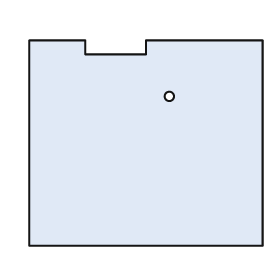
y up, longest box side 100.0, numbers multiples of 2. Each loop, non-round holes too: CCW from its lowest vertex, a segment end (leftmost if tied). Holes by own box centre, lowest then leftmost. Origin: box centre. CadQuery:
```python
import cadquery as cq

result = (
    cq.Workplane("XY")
    .moveTo(-50.0, -44.0)
    .lineTo(50.0, -44.0)
    .lineTo(50.0, 44.0)
    .lineTo(0.0, 44.0)
    .lineTo(0.0, 38.0)
    .lineTo(-26.0, 38.0)
    .lineTo(-26.0, 44.0)
    .lineTo(-50.0, 44.0)
    .close()
    .moveTo(10.0, 20.0)
    .circle(2.0)
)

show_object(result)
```